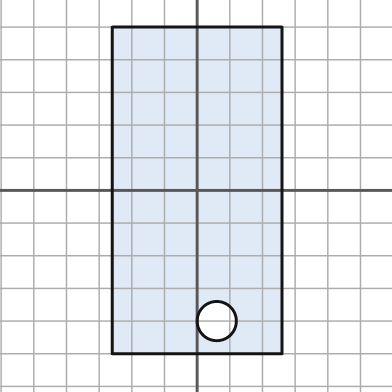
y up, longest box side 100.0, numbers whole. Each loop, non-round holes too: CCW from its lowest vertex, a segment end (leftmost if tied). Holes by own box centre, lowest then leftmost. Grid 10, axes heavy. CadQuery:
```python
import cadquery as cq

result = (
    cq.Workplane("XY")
    .moveTo(-26.0, -50.0)
    .lineTo(26.0, -50.0)
    .lineTo(26.0, 50.0)
    .lineTo(-26.0, 50.0)
    .close()
    .moveTo(6.0, -40.0)
    .circle(6.0)
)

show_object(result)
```